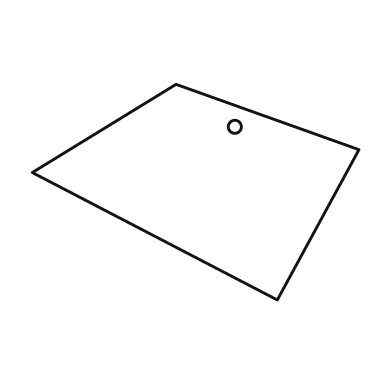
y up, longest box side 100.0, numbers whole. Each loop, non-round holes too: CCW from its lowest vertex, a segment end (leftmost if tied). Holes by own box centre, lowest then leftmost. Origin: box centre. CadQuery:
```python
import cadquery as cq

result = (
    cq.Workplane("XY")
    .moveTo(25.0, -33.0)
    .lineTo(50.0, 13.0)
    .lineTo(-6.0, 33.0)
    .lineTo(-50.0, 6.0)
    .close()
    .moveTo(12.0, 20.0)
    .circle(2.0)
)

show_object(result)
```